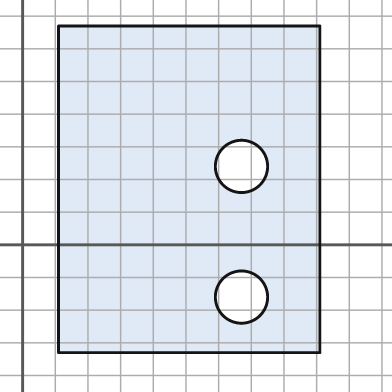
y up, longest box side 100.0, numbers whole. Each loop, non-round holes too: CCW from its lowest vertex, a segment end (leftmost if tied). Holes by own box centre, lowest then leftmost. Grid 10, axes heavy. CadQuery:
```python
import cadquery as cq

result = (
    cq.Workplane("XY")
    .moveTo(11.0, -33.0)
    .lineTo(91.0, -33.0)
    .lineTo(91.0, 67.0)
    .lineTo(11.0, 67.0)
    .close()
    .moveTo(67.0, -16.0)
    .circle(8.0)
    .moveTo(67.0, 24.0)
    .circle(8.0)
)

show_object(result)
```